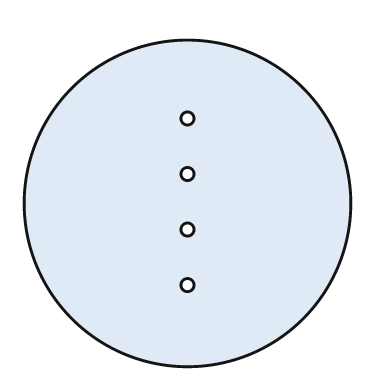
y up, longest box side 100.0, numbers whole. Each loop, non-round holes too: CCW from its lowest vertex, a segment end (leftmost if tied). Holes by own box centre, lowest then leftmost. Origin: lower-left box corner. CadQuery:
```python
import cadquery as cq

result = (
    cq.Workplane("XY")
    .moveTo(50.0, 50.0)
    .circle(50.0)
    .moveTo(50.0, 25.0)
    .circle(2.0)
    .moveTo(50.0, 42.0)
    .circle(2.0)
    .moveTo(50.0, 59.0)
    .circle(2.0)
    .moveTo(50.0, 76.0)
    .circle(2.0)
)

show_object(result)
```